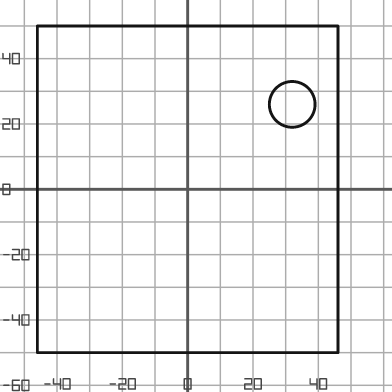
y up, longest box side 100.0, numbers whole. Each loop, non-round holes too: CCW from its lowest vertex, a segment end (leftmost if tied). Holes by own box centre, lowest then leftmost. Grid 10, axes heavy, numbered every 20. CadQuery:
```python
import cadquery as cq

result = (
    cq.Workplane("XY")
    .moveTo(-46.0, -50.0)
    .lineTo(46.0, -50.0)
    .lineTo(46.0, 50.0)
    .lineTo(-46.0, 50.0)
    .close()
    .moveTo(32.0, 26.0)
    .circle(7.0)
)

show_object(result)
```